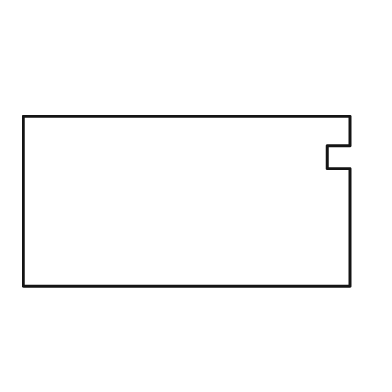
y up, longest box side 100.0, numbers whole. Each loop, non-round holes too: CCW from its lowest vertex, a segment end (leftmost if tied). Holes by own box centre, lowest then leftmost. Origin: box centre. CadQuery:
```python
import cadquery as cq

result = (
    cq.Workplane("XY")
    .moveTo(-50.0, -26.0)
    .lineTo(50.0, -26.0)
    .lineTo(50.0, 10.0)
    .lineTo(43.0, 10.0)
    .lineTo(43.0, 17.0)
    .lineTo(50.0, 17.0)
    .lineTo(50.0, 26.0)
    .lineTo(-50.0, 26.0)
    .close()
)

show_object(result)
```